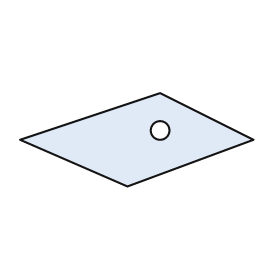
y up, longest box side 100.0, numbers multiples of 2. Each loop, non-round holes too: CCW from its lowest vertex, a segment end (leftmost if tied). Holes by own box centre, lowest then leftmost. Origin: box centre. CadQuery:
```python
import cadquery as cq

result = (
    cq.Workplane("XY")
    .moveTo(-4.0, -20.0)
    .lineTo(50.0, 0.0)
    .lineTo(10.0, 20.0)
    .lineTo(-50.0, 0.0)
    .close()
    .moveTo(10.0, 4.0)
    .circle(4.0)
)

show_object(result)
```